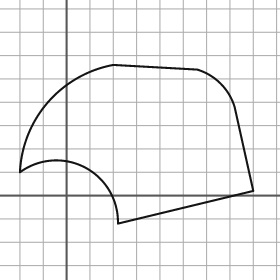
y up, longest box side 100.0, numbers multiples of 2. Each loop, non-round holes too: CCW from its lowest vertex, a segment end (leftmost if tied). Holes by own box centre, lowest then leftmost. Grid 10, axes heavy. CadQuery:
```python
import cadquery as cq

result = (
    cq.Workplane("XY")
    .moveTo(22.0, -12.0)
    .lineTo(80.0, 2.0)
    .lineTo(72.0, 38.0)
    .threePointArc((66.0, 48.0), (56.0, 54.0))
    .lineTo(20.0, 56.0)
    .threePointArc((-8.0, 40.0), (-20.0, 10.0))
    .threePointArc((8.0, 12.0), (22.0, -12.0))
    .close()
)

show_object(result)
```